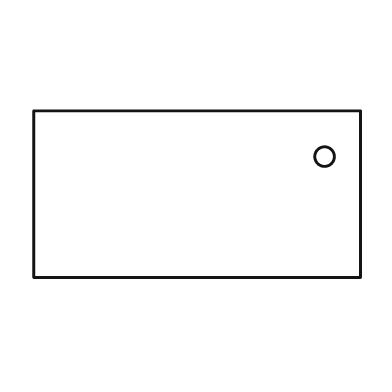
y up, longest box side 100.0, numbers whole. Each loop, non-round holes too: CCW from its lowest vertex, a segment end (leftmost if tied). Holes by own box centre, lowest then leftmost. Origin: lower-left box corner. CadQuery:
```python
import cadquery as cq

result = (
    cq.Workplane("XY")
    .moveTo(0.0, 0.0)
    .lineTo(100.0, 0.0)
    .lineTo(100.0, 51.0)
    .lineTo(0.0, 51.0)
    .close()
    .moveTo(89.0, 37.0)
    .circle(3.0)
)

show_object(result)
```